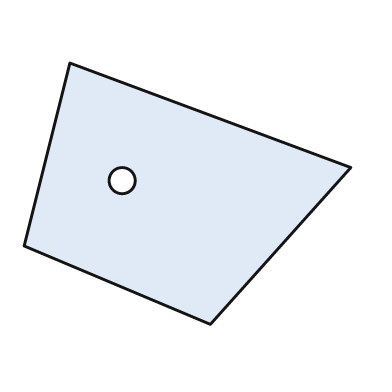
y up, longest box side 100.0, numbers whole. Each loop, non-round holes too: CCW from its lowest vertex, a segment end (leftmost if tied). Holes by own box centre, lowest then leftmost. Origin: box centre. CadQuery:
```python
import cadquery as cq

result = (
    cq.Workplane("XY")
    .moveTo(7.0, -40.0)
    .lineTo(50.0, 8.0)
    .lineTo(-36.0, 40.0)
    .lineTo(-50.0, -16.0)
    .close()
    .moveTo(-20.0, 4.0)
    .circle(4.0)
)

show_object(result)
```